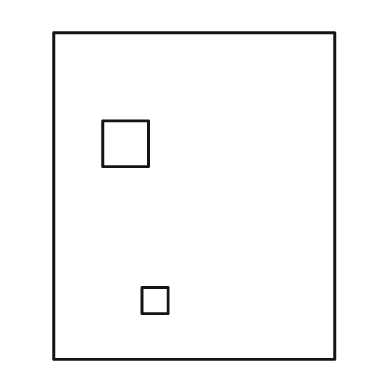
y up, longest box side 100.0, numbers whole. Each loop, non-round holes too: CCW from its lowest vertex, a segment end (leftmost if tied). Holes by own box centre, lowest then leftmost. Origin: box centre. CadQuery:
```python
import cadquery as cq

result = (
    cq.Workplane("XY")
    .moveTo(-43.0, -50.0)
    .lineTo(43.0, -50.0)
    .lineTo(43.0, 50.0)
    .lineTo(-43.0, 50.0)
    .close()
    .moveTo(-16.0, -36.0)
    .lineTo(-8.0, -36.0)
    .lineTo(-8.0, -28.0)
    .lineTo(-16.0, -28.0)
    .close()
    .moveTo(-28.0, 9.0)
    .lineTo(-14.0, 9.0)
    .lineTo(-14.0, 23.0)
    .lineTo(-28.0, 23.0)
    .close()
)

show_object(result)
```